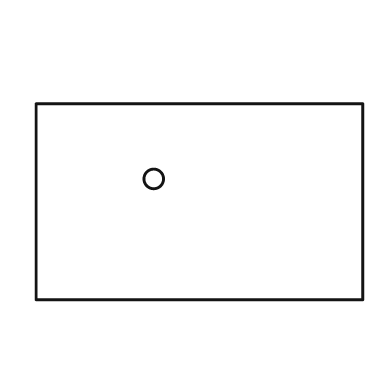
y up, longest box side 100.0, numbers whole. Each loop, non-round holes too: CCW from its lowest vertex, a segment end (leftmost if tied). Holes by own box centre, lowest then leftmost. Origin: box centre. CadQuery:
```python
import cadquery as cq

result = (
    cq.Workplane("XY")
    .moveTo(-50.0, -30.0)
    .lineTo(50.0, -30.0)
    .lineTo(50.0, 30.0)
    .lineTo(-50.0, 30.0)
    .close()
    .moveTo(-14.0, 7.0)
    .circle(3.0)
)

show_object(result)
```